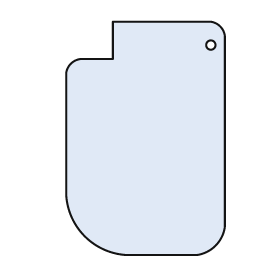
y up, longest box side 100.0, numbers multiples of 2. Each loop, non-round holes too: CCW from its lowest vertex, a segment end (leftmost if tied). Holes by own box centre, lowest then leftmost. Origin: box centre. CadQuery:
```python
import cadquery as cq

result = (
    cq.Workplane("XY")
    .moveTo(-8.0, -50.0)
    .lineTo(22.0, -50.0)
    .threePointArc((30.0, -46.0), (34.0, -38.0))
    .lineTo(34.0, 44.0)
    .threePointArc((32.0, 48.0), (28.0, 50.0))
    .lineTo(-14.0, 50.0)
    .lineTo(-14.0, 34.0)
    .lineTo(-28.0, 34.0)
    .threePointArc((-32.0, 32.0), (-34.0, 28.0))
    .lineTo(-34.0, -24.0)
    .threePointArc((-26.0, -42.0), (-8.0, -50.0))
    .close()
    .moveTo(28.0, 40.0)
    .circle(2.0)
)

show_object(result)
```